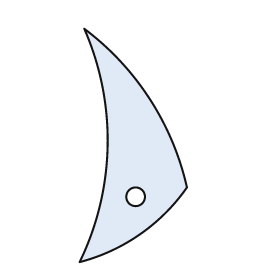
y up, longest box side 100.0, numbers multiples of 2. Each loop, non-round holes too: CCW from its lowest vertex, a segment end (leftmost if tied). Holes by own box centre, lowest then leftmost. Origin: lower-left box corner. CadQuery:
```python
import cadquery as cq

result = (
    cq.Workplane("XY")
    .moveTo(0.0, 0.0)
    .threePointArc((26.0, 12.0), (46.0, 32.0))
    .threePointArc((30.0, 70.0), (2.0, 100.0))
    .threePointArc((12.0, 50.0), (0.0, 0.0))
    .close()
    .moveTo(24.0, 28.0)
    .circle(4.0)
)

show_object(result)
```